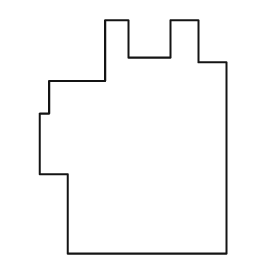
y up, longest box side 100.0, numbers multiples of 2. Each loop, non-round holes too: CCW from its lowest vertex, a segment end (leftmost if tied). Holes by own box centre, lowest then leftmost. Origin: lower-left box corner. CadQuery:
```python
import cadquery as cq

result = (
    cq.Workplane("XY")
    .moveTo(12.0, 0.0)
    .lineTo(80.0, 0.0)
    .lineTo(80.0, 82.0)
    .lineTo(68.0, 82.0)
    .lineTo(68.0, 100.0)
    .lineTo(56.0, 100.0)
    .lineTo(56.0, 84.0)
    .lineTo(38.0, 84.0)
    .lineTo(38.0, 100.0)
    .lineTo(28.0, 100.0)
    .lineTo(28.0, 74.0)
    .lineTo(4.0, 74.0)
    .lineTo(4.0, 60.0)
    .lineTo(0.0, 60.0)
    .lineTo(0.0, 34.0)
    .lineTo(12.0, 34.0)
    .close()
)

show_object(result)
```